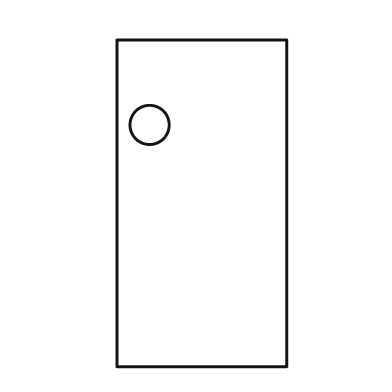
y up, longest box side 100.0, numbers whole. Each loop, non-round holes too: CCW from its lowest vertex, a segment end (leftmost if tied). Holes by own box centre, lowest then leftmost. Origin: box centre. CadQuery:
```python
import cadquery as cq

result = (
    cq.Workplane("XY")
    .moveTo(-26.0, -50.0)
    .lineTo(26.0, -50.0)
    .lineTo(26.0, 50.0)
    .lineTo(-26.0, 50.0)
    .close()
    .moveTo(-16.0, 24.0)
    .circle(6.0)
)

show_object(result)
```